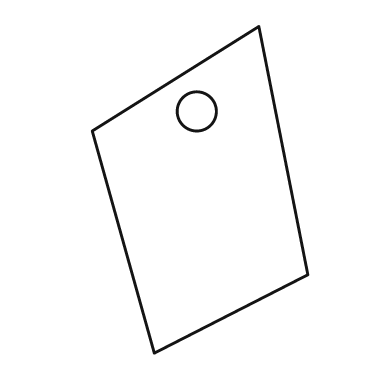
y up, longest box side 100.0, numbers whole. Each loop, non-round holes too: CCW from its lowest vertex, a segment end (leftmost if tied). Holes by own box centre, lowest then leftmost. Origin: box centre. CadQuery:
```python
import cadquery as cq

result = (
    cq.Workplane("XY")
    .moveTo(-14.0, -50.0)
    .lineTo(33.0, -26.0)
    .lineTo(18.0, 50.0)
    .lineTo(-33.0, 18.0)
    .close()
    .moveTo(-1.0, 24.0)
    .circle(6.0)
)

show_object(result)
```